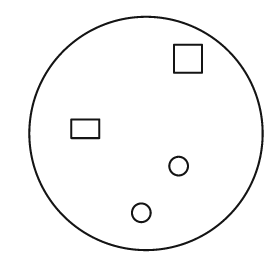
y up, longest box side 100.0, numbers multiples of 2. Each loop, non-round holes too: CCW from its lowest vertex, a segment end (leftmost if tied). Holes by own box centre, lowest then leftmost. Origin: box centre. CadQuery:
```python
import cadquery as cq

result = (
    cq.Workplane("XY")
    .moveTo(0.0, 0.0)
    .circle(50.0)
    .moveTo(-2.0, -34.0)
    .circle(4.0)
    .moveTo(14.0, -14.0)
    .circle(4.0)
    .moveTo(-32.0, -2.0)
    .lineTo(-20.0, -2.0)
    .lineTo(-20.0, 6.0)
    .lineTo(-32.0, 6.0)
    .close()
    .moveTo(12.0, 26.0)
    .lineTo(24.0, 26.0)
    .lineTo(24.0, 38.0)
    .lineTo(12.0, 38.0)
    .close()
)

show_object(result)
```